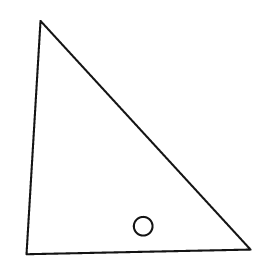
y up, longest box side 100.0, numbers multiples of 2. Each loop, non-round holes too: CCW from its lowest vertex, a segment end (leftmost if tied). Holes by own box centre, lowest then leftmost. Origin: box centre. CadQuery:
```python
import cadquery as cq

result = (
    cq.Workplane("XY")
    .moveTo(-48.0, -50.0)
    .lineTo(48.0, -48.0)
    .lineTo(-42.0, 50.0)
    .close()
    .moveTo(2.0, -38.0)
    .circle(4.0)
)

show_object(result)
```